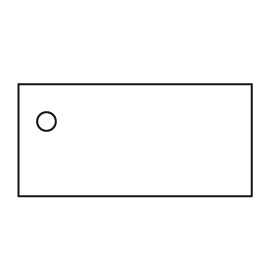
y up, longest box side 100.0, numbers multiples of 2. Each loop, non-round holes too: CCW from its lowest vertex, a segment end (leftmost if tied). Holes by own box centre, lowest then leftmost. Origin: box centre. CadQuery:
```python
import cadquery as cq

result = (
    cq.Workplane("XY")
    .moveTo(-50.0, -24.0)
    .lineTo(50.0, -24.0)
    .lineTo(50.0, 24.0)
    .lineTo(-50.0, 24.0)
    .close()
    .moveTo(-38.0, 8.0)
    .circle(4.0)
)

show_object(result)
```